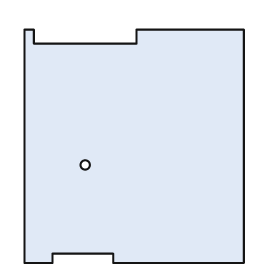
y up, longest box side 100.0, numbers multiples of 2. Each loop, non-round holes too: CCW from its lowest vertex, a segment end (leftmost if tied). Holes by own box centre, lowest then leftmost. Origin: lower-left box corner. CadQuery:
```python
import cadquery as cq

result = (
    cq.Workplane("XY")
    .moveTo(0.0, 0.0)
    .lineTo(12.0, 0.0)
    .lineTo(12.0, 4.0)
    .lineTo(38.0, 4.0)
    .lineTo(38.0, 0.0)
    .lineTo(94.0, 0.0)
    .lineTo(94.0, 100.0)
    .lineTo(48.0, 100.0)
    .lineTo(48.0, 94.0)
    .lineTo(4.0, 94.0)
    .lineTo(4.0, 100.0)
    .lineTo(0.0, 100.0)
    .close()
    .moveTo(26.0, 42.0)
    .circle(2.0)
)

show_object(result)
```